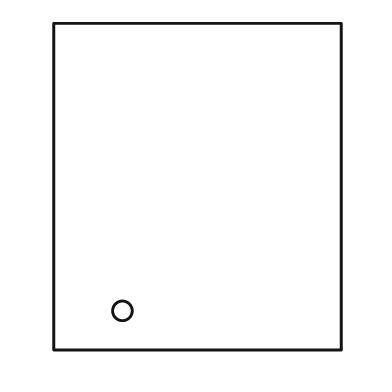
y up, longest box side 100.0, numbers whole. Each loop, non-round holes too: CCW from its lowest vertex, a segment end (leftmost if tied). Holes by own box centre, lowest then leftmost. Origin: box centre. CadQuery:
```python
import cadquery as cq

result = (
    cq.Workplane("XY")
    .moveTo(-44.0, -50.0)
    .lineTo(44.0, -50.0)
    .lineTo(44.0, 50.0)
    .lineTo(-44.0, 50.0)
    .close()
    .moveTo(-23.0, -38.0)
    .circle(3.0)
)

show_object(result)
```